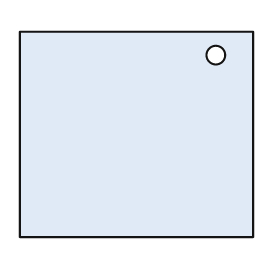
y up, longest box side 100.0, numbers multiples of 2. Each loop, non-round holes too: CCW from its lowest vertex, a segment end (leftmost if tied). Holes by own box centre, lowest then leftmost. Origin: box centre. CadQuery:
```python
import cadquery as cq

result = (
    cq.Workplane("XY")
    .moveTo(-50.0, -44.0)
    .lineTo(50.0, -44.0)
    .lineTo(50.0, 44.0)
    .lineTo(-50.0, 44.0)
    .close()
    .moveTo(34.0, 34.0)
    .circle(4.0)
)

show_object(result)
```